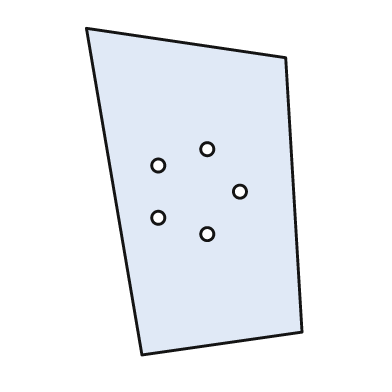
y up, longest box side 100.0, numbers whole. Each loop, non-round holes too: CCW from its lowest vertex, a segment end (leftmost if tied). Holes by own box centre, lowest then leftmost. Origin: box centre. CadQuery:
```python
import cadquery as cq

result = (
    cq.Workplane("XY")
    .moveTo(-16.0, -50.0)
    .lineTo(33.0, -43.0)
    .lineTo(28.0, 41.0)
    .lineTo(-33.0, 50.0)
    .close()
    .moveTo(4.0, -13.0)
    .circle(2.0)
    .moveTo(-11.0, -8.0)
    .circle(2.0)
    .moveTo(14.0, 0.0)
    .circle(2.0)
    .moveTo(-11.0, 8.0)
    .circle(2.0)
    .moveTo(4.0, 13.0)
    .circle(2.0)
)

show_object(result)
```